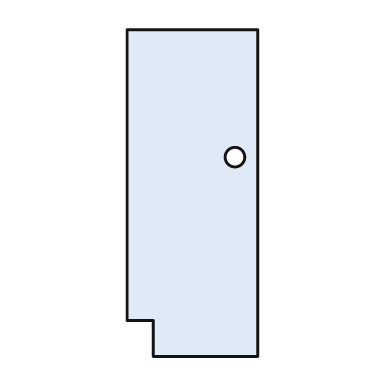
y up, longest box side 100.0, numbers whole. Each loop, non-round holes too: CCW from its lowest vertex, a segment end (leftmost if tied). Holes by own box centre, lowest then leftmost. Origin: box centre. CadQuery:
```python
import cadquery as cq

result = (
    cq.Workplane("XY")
    .moveTo(-12.0, -50.0)
    .lineTo(20.0, -50.0)
    .lineTo(20.0, 50.0)
    .lineTo(-20.0, 50.0)
    .lineTo(-20.0, -39.0)
    .lineTo(-12.0, -39.0)
    .close()
    .moveTo(13.0, 11.0)
    .circle(3.0)
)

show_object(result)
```